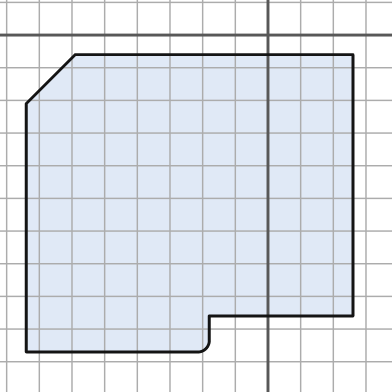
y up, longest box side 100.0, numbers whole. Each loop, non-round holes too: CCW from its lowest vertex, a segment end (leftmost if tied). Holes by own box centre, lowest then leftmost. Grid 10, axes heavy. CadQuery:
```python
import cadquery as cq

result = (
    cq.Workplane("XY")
    .moveTo(-74.0, -97.0)
    .lineTo(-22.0, -97.0)
    .threePointArc((-19.0, -96.0), (-18.0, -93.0))
    .lineTo(-18.0, -86.0)
    .lineTo(26.0, -86.0)
    .lineTo(26.0, -6.0)
    .lineTo(-59.0, -6.0)
    .lineTo(-74.0, -21.0)
    .close()
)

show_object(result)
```